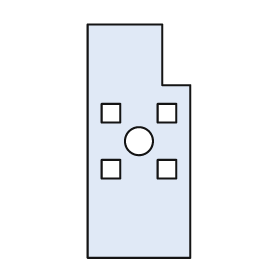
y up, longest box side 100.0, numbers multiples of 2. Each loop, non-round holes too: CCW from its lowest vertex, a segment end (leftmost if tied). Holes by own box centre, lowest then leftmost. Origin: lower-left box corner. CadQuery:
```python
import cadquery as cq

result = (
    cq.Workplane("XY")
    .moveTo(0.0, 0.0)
    .lineTo(44.0, 0.0)
    .lineTo(44.0, 74.0)
    .lineTo(32.0, 74.0)
    .lineTo(32.0, 100.0)
    .lineTo(0.0, 100.0)
    .close()
    .moveTo(6.0, 34.0)
    .lineTo(14.0, 34.0)
    .lineTo(14.0, 42.0)
    .lineTo(6.0, 42.0)
    .close()
    .moveTo(30.0, 34.0)
    .lineTo(38.0, 34.0)
    .lineTo(38.0, 42.0)
    .lineTo(30.0, 42.0)
    .close()
    .moveTo(22.0, 50.0)
    .circle(6.0)
    .moveTo(6.0, 58.0)
    .lineTo(14.0, 58.0)
    .lineTo(14.0, 66.0)
    .lineTo(6.0, 66.0)
    .close()
    .moveTo(30.0, 58.0)
    .lineTo(38.0, 58.0)
    .lineTo(38.0, 66.0)
    .lineTo(30.0, 66.0)
    .close()
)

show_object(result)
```